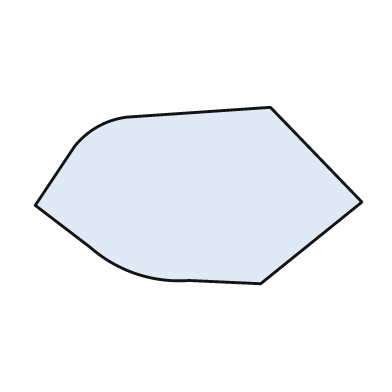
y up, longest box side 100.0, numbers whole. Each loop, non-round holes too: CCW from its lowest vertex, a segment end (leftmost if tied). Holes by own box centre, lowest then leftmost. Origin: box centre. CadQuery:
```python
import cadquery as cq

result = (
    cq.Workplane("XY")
    .moveTo(19.0, -27.0)
    .lineTo(50.0, -2.0)
    .lineTo(22.0, 27.0)
    .lineTo(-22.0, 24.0)
    .threePointArc((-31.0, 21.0), (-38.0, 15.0))
    .lineTo(-50.0, -3.0)
    .lineTo(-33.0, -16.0)
    .threePointArc((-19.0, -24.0), (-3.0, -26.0))
    .close()
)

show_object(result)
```